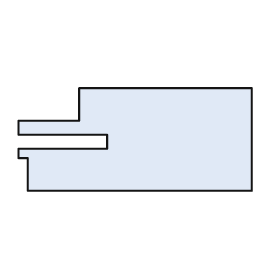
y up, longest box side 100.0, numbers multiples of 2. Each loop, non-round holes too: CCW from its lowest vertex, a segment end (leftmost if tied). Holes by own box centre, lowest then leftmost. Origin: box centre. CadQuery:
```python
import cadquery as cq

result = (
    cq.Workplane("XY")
    .moveTo(-46.0, -22.0)
    .lineTo(50.0, -22.0)
    .lineTo(50.0, 22.0)
    .lineTo(-24.0, 22.0)
    .lineTo(-24.0, 8.0)
    .lineTo(-50.0, 8.0)
    .lineTo(-50.0, 2.0)
    .lineTo(-12.0, 2.0)
    .lineTo(-12.0, -4.0)
    .lineTo(-50.0, -4.0)
    .lineTo(-50.0, -8.0)
    .lineTo(-46.0, -8.0)
    .close()
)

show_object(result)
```